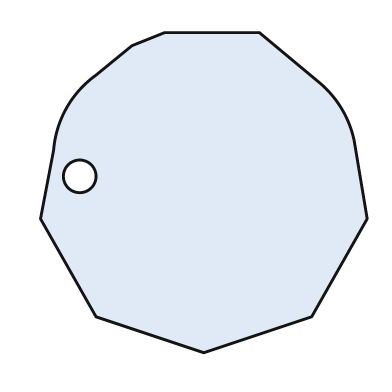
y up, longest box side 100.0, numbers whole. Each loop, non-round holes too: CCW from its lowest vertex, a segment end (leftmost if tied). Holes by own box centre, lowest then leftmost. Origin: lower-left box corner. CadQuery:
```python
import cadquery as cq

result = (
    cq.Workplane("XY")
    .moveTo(50.0, 0.0)
    .lineTo(83.0, 11.0)
    .lineTo(100.0, 41.0)
    .lineTo(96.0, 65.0)
    .threePointArc((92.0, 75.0), (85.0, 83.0))
    .lineTo(67.0, 98.0)
    .lineTo(38.0, 98.0)
    .lineTo(28.0, 94.0)
    .lineTo(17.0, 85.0)
    .threePointArc((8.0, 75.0), (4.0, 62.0))
    .lineTo(0.0, 41.0)
    .lineTo(17.0, 11.0)
    .close()
    .moveTo(12.0, 54.0)
    .circle(5.0)
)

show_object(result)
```